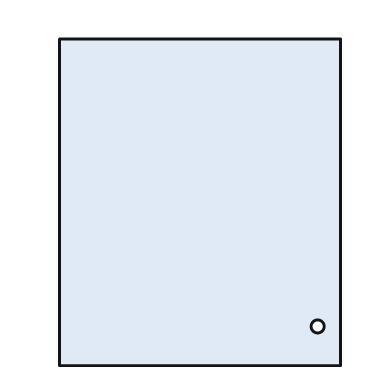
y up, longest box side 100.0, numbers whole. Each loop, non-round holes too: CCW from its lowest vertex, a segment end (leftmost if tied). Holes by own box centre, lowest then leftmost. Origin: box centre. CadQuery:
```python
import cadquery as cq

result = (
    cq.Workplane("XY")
    .moveTo(-43.0, -50.0)
    .lineTo(43.0, -50.0)
    .lineTo(43.0, 50.0)
    .lineTo(-43.0, 50.0)
    .close()
    .moveTo(36.0, -38.0)
    .circle(2.0)
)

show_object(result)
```